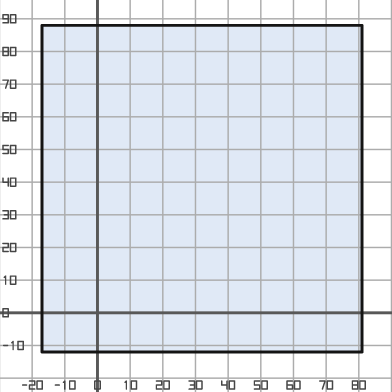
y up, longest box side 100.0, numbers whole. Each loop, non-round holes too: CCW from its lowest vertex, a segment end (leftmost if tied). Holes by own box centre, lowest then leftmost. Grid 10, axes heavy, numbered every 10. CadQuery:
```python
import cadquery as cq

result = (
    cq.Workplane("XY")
    .moveTo(-17.0, -12.0)
    .lineTo(81.0, -12.0)
    .lineTo(81.0, 88.0)
    .lineTo(-17.0, 88.0)
    .close()
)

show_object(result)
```